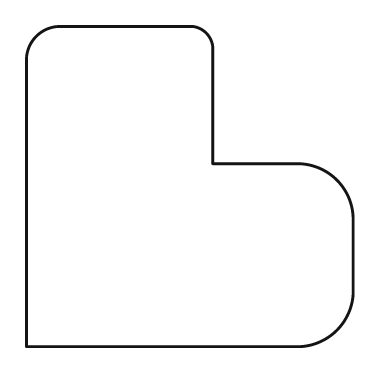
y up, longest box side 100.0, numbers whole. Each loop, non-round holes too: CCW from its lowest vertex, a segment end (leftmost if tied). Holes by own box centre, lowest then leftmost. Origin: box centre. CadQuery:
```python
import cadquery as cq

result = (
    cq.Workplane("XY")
    .moveTo(-50.0, -49.0)
    .lineTo(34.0, -49.0)
    .threePointArc((45.0, -44.0), (50.0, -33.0))
    .lineTo(50.0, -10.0)
    .threePointArc((45.0, 2.0), (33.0, 7.0))
    .lineTo(7.0, 7.0)
    .lineTo(7.0, 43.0)
    .threePointArc((5.0, 47.0), (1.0, 49.0))
    .lineTo(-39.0, 49.0)
    .threePointArc((-47.0, 46.0), (-50.0, 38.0))
    .close()
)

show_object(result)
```